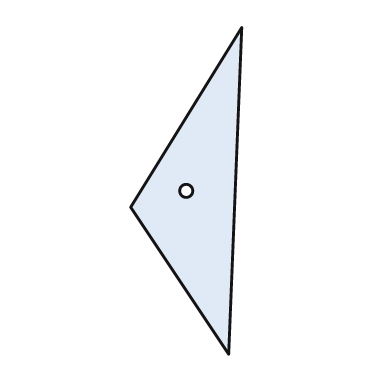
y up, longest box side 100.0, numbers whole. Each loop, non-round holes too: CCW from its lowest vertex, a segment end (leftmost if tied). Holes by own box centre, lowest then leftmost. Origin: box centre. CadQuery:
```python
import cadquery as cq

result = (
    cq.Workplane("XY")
    .moveTo(13.0, -50.0)
    .lineTo(17.0, 50.0)
    .lineTo(-17.0, -5.0)
    .close()
    .moveTo(0.0, 0.0)
    .circle(2.0)
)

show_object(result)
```